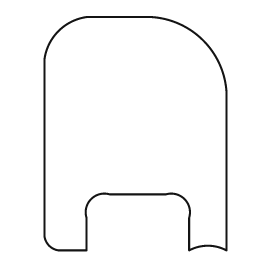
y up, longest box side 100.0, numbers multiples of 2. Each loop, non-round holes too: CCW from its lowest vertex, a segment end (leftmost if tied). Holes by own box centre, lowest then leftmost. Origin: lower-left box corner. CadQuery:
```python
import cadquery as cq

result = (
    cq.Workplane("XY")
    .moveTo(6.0, 0.0)
    .lineTo(18.0, 0.0)
    .lineTo(18.0, 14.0)
    .threePointArc((20.0, 22.0), (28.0, 24.0))
    .lineTo(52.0, 24.0)
    .threePointArc((60.0, 22.0), (62.0, 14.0))
    .lineTo(62.0, 0.0)
    .threePointArc((70.0, 2.0), (78.0, 0.0))
    .lineTo(78.0, 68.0)
    .threePointArc((68.0, 90.0), (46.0, 100.0))
    .lineTo(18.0, 100.0)
    .threePointArc((6.0, 94.0), (0.0, 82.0))
    .lineTo(0.0, 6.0)
    .threePointArc((2.0, 2.0), (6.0, 0.0))
    .close()
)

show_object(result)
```